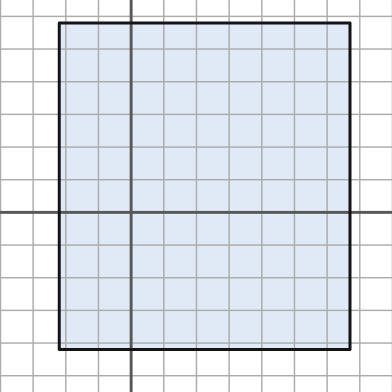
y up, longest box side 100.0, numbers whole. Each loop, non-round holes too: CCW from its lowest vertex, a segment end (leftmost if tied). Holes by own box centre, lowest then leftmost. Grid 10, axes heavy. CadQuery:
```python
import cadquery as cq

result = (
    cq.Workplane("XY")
    .moveTo(-22.0, -42.0)
    .lineTo(67.0, -42.0)
    .lineTo(67.0, 58.0)
    .lineTo(-22.0, 58.0)
    .close()
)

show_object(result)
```